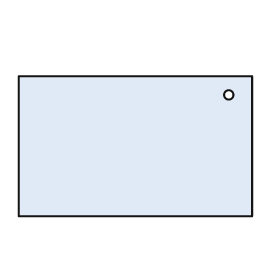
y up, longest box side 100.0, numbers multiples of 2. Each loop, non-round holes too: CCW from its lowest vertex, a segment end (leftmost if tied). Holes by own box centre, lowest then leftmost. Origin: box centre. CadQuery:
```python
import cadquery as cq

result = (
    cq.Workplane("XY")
    .moveTo(-50.0, -30.0)
    .lineTo(50.0, -30.0)
    .lineTo(50.0, 30.0)
    .lineTo(-50.0, 30.0)
    .close()
    .moveTo(40.0, 22.0)
    .circle(2.0)
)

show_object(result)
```